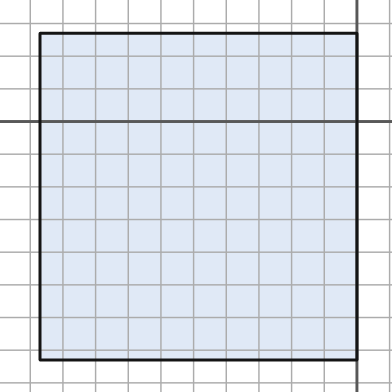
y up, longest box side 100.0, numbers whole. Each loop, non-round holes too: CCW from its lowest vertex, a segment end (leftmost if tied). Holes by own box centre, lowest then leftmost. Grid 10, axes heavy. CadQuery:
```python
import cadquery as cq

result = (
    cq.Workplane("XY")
    .moveTo(-97.0, -73.0)
    .lineTo(0.0, -73.0)
    .lineTo(0.0, 27.0)
    .lineTo(-97.0, 27.0)
    .close()
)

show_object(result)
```